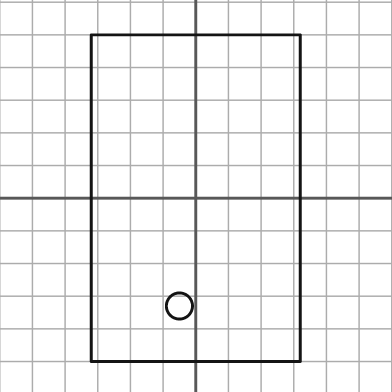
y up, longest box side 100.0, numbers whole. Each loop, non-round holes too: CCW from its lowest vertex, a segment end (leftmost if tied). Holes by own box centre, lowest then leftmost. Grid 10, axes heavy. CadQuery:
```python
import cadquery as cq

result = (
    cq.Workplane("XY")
    .moveTo(-32.0, -50.0)
    .lineTo(32.0, -50.0)
    .lineTo(32.0, 50.0)
    .lineTo(-32.0, 50.0)
    .close()
    .moveTo(-5.0, -33.0)
    .circle(4.0)
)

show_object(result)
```